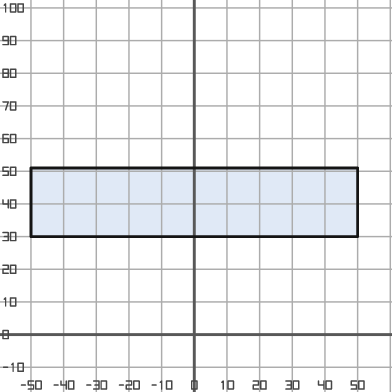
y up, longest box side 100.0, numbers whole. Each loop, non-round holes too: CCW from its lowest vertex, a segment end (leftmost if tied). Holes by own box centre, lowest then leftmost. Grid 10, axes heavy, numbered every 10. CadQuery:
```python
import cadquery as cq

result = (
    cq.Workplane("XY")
    .moveTo(-50.0, 30.0)
    .lineTo(50.0, 30.0)
    .lineTo(50.0, 51.0)
    .lineTo(-50.0, 51.0)
    .close()
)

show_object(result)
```